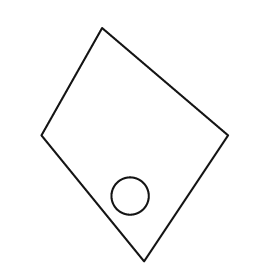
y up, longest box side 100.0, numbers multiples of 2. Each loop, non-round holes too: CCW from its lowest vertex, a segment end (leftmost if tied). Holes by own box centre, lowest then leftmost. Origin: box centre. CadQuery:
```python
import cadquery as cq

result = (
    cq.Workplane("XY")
    .moveTo(4.0, -50.0)
    .lineTo(40.0, 4.0)
    .lineTo(-14.0, 50.0)
    .lineTo(-40.0, 4.0)
    .close()
    .moveTo(-2.0, -22.0)
    .circle(8.0)
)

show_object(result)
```